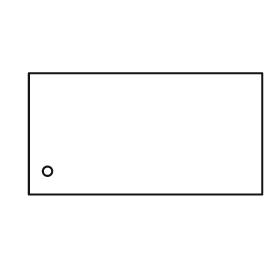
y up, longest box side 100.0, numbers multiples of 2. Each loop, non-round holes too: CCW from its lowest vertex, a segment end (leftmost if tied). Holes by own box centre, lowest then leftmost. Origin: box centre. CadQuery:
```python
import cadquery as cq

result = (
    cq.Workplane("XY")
    .moveTo(-50.0, -26.0)
    .lineTo(50.0, -26.0)
    .lineTo(50.0, 26.0)
    .lineTo(-50.0, 26.0)
    .close()
    .moveTo(-42.0, -16.0)
    .circle(2.0)
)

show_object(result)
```